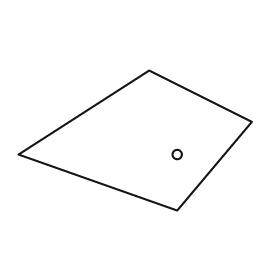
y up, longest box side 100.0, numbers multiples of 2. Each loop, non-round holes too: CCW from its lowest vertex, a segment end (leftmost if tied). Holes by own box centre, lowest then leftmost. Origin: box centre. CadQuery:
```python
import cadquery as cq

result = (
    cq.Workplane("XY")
    .moveTo(18.0, -30.0)
    .lineTo(50.0, 8.0)
    .lineTo(6.0, 30.0)
    .lineTo(-50.0, -6.0)
    .close()
    .moveTo(18.0, -6.0)
    .circle(2.0)
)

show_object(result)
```